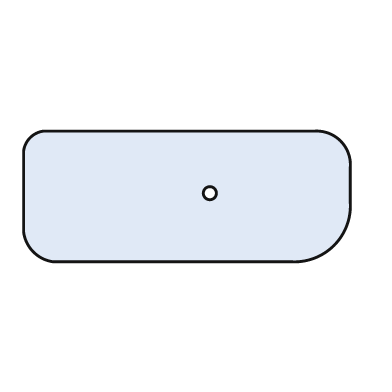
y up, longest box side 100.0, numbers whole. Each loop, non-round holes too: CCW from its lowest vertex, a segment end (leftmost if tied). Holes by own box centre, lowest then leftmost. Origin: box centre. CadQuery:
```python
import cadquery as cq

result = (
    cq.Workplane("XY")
    .moveTo(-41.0, -20.0)
    .lineTo(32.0, -20.0)
    .threePointArc((45.0, -15.0), (50.0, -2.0))
    .lineTo(50.0, 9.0)
    .threePointArc((47.0, 17.0), (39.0, 20.0))
    .lineTo(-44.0, 20.0)
    .threePointArc((-48.0, 18.0), (-50.0, 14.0))
    .lineTo(-50.0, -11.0)
    .threePointArc((-47.0, -17.0), (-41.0, -20.0))
    .close()
    .moveTo(7.0, 1.0)
    .circle(2.0)
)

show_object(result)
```